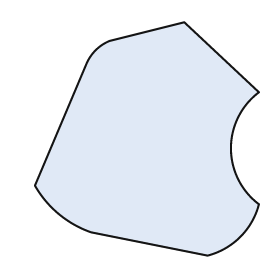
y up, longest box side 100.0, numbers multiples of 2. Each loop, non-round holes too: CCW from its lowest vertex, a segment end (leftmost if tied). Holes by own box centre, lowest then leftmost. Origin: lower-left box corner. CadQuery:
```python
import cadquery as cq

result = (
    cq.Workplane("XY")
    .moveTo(74.0, 0.0)
    .threePointArc((88.0, 8.0), (96.0, 22.0))
    .threePointArc((84.0, 46.0), (96.0, 70.0))
    .lineTo(64.0, 100.0)
    .lineTo(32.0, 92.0)
    .threePointArc((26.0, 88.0), (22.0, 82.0))
    .lineTo(0.0, 30.0)
    .threePointArc((10.0, 18.0), (24.0, 10.0))
    .close()
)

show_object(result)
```